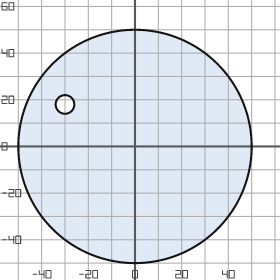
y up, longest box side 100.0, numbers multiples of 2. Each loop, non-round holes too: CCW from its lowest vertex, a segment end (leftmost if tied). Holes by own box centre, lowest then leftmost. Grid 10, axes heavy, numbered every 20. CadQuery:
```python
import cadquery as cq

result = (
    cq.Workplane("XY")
    .moveTo(0.0, 0.0)
    .circle(50.0)
    .moveTo(-30.0, 18.0)
    .circle(4.0)
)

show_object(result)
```